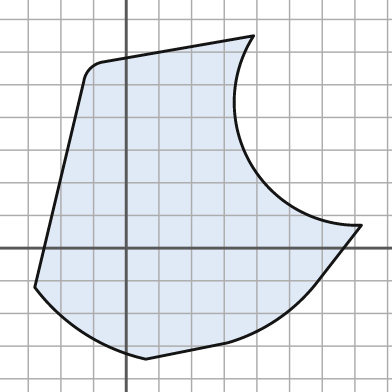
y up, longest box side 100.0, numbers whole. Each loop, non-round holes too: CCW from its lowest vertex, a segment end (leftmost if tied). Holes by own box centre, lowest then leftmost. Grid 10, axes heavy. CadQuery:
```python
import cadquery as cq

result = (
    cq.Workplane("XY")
    .moveTo(6.0, -34.0)
    .lineTo(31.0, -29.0)
    .threePointArc((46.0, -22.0), (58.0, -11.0))
    .lineTo(72.0, 7.0)
    .threePointArc((38.0, 26.0), (39.0, 65.0))
    .lineTo(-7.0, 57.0)
    .threePointArc((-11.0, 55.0), (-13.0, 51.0))
    .lineTo(-28.0, -12.0)
    .threePointArc((-13.0, -26.0), (6.0, -34.0))
    .close()
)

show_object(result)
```